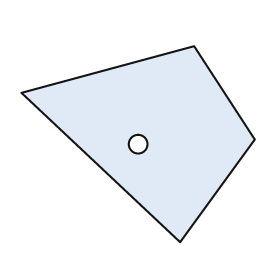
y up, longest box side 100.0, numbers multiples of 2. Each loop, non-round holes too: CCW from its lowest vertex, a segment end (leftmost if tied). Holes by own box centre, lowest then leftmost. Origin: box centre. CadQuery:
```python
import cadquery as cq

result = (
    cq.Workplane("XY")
    .moveTo(18.0, -42.0)
    .lineTo(50.0, 2.0)
    .lineTo(24.0, 42.0)
    .lineTo(-50.0, 22.0)
    .close()
    .moveTo(0.0, 0.0)
    .circle(4.0)
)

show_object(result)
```